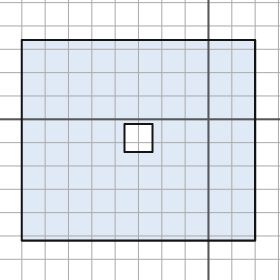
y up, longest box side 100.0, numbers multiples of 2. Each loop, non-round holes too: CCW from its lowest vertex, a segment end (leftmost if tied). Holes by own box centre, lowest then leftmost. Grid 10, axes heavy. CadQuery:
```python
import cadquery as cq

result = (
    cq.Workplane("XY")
    .moveTo(-80.0, -52.0)
    .lineTo(20.0, -52.0)
    .lineTo(20.0, 34.0)
    .lineTo(-80.0, 34.0)
    .close()
    .moveTo(-36.0, -14.0)
    .lineTo(-24.0, -14.0)
    .lineTo(-24.0, -2.0)
    .lineTo(-36.0, -2.0)
    .close()
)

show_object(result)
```